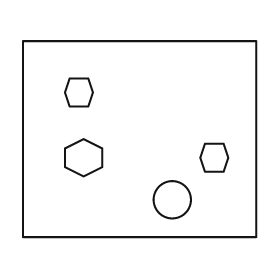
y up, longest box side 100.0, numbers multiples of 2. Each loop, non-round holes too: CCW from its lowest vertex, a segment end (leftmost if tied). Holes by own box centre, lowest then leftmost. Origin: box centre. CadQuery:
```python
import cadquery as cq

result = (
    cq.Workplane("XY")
    .moveTo(-50.0, -42.0)
    .lineTo(50.0, -42.0)
    .lineTo(50.0, 42.0)
    .lineTo(-50.0, 42.0)
    .close()
    .moveTo(14.0, -26.0)
    .circle(8.0)
    .moveTo(-24.0, -16.0)
    .lineTo(-16.0, -12.0)
    .lineTo(-16.0, -4.0)
    .lineTo(-24.0, 0.0)
    .lineTo(-32.0, -4.0)
    .lineTo(-32.0, -12.0)
    .close()
    .moveTo(28.0, -14.0)
    .lineTo(36.0, -14.0)
    .lineTo(38.0, -8.0)
    .lineTo(36.0, -2.0)
    .lineTo(28.0, -2.0)
    .lineTo(26.0, -8.0)
    .close()
    .moveTo(-30.0, 14.0)
    .lineTo(-22.0, 14.0)
    .lineTo(-20.0, 20.0)
    .lineTo(-22.0, 26.0)
    .lineTo(-30.0, 26.0)
    .lineTo(-32.0, 20.0)
    .close()
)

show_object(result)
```